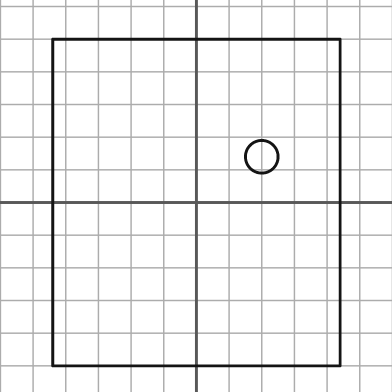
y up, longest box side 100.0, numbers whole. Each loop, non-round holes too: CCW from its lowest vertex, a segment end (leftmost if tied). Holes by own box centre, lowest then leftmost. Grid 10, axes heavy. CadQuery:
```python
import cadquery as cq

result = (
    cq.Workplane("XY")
    .moveTo(-44.0, -50.0)
    .lineTo(44.0, -50.0)
    .lineTo(44.0, 50.0)
    .lineTo(-44.0, 50.0)
    .close()
    .moveTo(20.0, 14.0)
    .circle(5.0)
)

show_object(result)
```